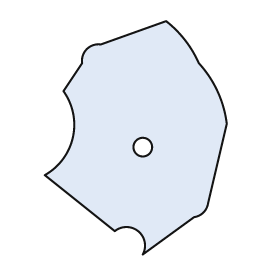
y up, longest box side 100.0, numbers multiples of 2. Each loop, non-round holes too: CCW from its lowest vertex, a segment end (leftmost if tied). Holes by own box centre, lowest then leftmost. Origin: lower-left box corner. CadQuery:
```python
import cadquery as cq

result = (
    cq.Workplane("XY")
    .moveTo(42.0, 0.0)
    .lineTo(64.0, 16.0)
    .threePointArc((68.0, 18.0), (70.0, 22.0))
    .lineTo(78.0, 56.0)
    .threePointArc((74.0, 70.0), (66.0, 82.0))
    .threePointArc((60.0, 92.0), (52.0, 100.0))
    .lineTo(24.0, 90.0)
    .threePointArc((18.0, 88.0), (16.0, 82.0))
    .lineTo(8.0, 70.0)
    .threePointArc((12.0, 50.0), (0.0, 34.0))
    .lineTo(30.0, 10.0)
    .threePointArc((40.0, 10.0), (42.0, 0.0))
    .close()
    .moveTo(42.0, 46.0)
    .circle(4.0)
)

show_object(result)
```